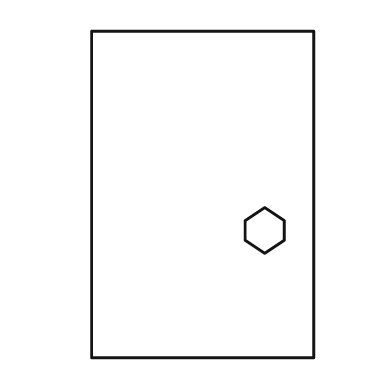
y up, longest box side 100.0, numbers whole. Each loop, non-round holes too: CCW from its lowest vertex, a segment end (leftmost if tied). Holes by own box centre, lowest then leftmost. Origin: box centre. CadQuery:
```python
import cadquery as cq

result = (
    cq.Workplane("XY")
    .moveTo(-34.0, -50.0)
    .lineTo(34.0, -50.0)
    .lineTo(34.0, 50.0)
    .lineTo(-34.0, 50.0)
    .close()
    .moveTo(19.0, -18.0)
    .lineTo(25.0, -14.0)
    .lineTo(25.0, -8.0)
    .lineTo(19.0, -4.0)
    .lineTo(13.0, -8.0)
    .lineTo(13.0, -14.0)
    .close()
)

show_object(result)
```